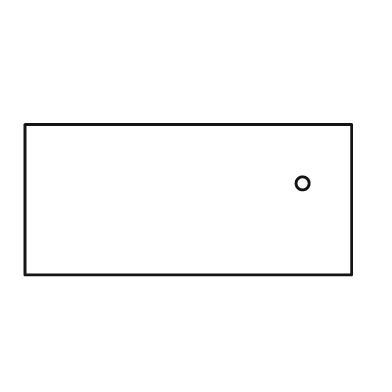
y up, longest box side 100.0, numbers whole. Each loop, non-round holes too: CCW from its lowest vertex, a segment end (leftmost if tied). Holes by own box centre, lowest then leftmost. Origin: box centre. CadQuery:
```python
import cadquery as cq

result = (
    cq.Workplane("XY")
    .moveTo(-50.0, -23.0)
    .lineTo(50.0, -23.0)
    .lineTo(50.0, 23.0)
    .lineTo(-50.0, 23.0)
    .close()
    .moveTo(35.0, 5.0)
    .circle(2.0)
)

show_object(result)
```